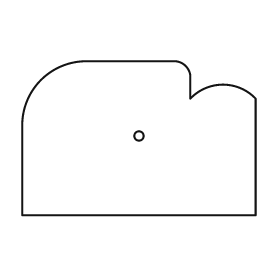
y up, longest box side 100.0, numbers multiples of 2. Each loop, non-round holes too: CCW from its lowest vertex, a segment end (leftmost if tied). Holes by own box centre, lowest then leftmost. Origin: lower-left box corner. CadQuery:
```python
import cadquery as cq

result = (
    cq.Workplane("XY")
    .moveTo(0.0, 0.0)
    .lineTo(100.0, 0.0)
    .lineTo(100.0, 50.0)
    .threePointArc((86.0, 56.0), (72.0, 50.0))
    .lineTo(72.0, 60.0)
    .threePointArc((70.0, 64.0), (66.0, 66.0))
    .lineTo(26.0, 66.0)
    .threePointArc((8.0, 58.0), (0.0, 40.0))
    .close()
    .moveTo(50.0, 34.0)
    .circle(2.0)
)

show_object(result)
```